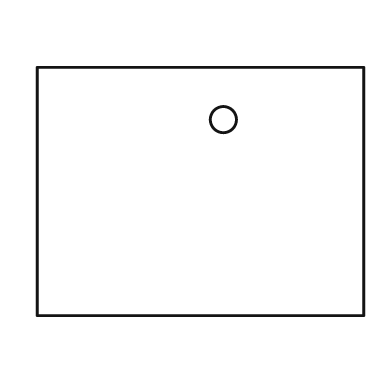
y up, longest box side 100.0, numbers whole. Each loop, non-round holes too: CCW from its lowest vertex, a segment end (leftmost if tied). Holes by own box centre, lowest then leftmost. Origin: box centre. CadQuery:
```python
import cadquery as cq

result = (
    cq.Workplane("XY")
    .moveTo(-50.0, -38.0)
    .lineTo(50.0, -38.0)
    .lineTo(50.0, 38.0)
    .lineTo(-50.0, 38.0)
    .close()
    .moveTo(7.0, 22.0)
    .circle(4.0)
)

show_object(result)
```